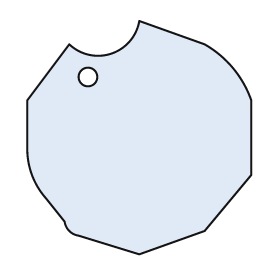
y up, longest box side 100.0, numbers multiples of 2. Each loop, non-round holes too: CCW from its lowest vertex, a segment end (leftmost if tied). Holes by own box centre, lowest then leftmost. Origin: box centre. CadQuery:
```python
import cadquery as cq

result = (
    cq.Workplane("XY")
    .moveTo(0.0, -50.0)
    .lineTo(28.0, -40.0)
    .lineTo(48.0, -16.0)
    .lineTo(48.0, 16.0)
    .threePointArc((40.0, 30.0), (28.0, 40.0))
    .lineTo(0.0, 50.0)
    .threePointArc((-12.0, 36.0), (-30.0, 40.0))
    .lineTo(-48.0, 16.0)
    .lineTo(-48.0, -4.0)
    .threePointArc((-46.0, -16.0), (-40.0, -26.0))
    .lineTo(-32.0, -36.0)
    .threePointArc((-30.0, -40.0), (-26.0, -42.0))
    .close()
    .moveTo(-22.0, 26.0)
    .circle(4.0)
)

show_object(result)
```